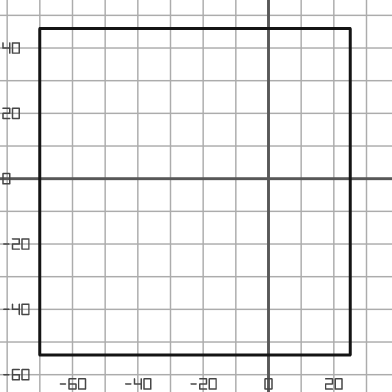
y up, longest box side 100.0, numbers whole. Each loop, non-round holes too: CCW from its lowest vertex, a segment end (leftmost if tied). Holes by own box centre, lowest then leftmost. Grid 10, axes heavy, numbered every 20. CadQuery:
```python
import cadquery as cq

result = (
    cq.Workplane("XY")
    .moveTo(-70.0, -54.0)
    .lineTo(25.0, -54.0)
    .lineTo(25.0, 46.0)
    .lineTo(-70.0, 46.0)
    .close()
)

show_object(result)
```